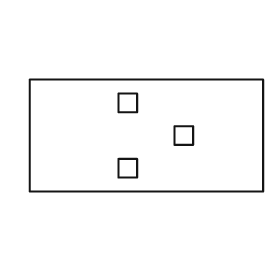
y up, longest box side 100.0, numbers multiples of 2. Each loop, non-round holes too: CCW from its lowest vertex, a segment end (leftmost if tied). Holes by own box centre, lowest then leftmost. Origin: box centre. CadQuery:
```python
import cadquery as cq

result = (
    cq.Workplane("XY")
    .moveTo(-50.0, -24.0)
    .lineTo(50.0, -24.0)
    .lineTo(50.0, 24.0)
    .lineTo(-50.0, 24.0)
    .close()
    .moveTo(-12.0, -18.0)
    .lineTo(-4.0, -18.0)
    .lineTo(-4.0, -10.0)
    .lineTo(-12.0, -10.0)
    .close()
    .moveTo(12.0, -4.0)
    .lineTo(20.0, -4.0)
    .lineTo(20.0, 4.0)
    .lineTo(12.0, 4.0)
    .close()
    .moveTo(-12.0, 10.0)
    .lineTo(-4.0, 10.0)
    .lineTo(-4.0, 18.0)
    .lineTo(-12.0, 18.0)
    .close()
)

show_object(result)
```